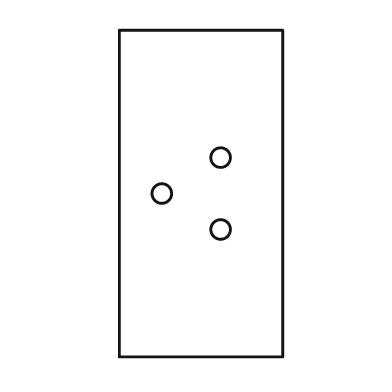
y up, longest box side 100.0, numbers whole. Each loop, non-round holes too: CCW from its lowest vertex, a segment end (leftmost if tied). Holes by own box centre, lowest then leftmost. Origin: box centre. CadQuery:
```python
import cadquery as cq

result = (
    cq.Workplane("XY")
    .moveTo(-25.0, -50.0)
    .lineTo(25.0, -50.0)
    .lineTo(25.0, 50.0)
    .lineTo(-25.0, 50.0)
    .close()
    .moveTo(6.0, -11.0)
    .circle(3.0)
    .moveTo(-12.0, 0.0)
    .circle(3.0)
    .moveTo(6.0, 11.0)
    .circle(3.0)
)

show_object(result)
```